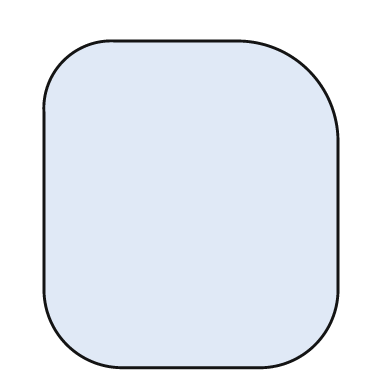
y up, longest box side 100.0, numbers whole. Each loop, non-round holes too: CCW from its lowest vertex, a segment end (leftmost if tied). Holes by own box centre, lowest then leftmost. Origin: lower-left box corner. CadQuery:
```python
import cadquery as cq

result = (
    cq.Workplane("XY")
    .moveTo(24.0, 0.0)
    .lineTo(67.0, 0.0)
    .threePointArc((83.0, 7.0), (90.0, 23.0))
    .lineTo(90.0, 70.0)
    .threePointArc((81.0, 91.0), (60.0, 100.0))
    .lineTo(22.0, 100.0)
    .threePointArc((6.0, 94.0), (0.0, 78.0))
    .lineTo(0.0, 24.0)
    .threePointArc((7.0, 7.0), (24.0, 0.0))
    .close()
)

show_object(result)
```